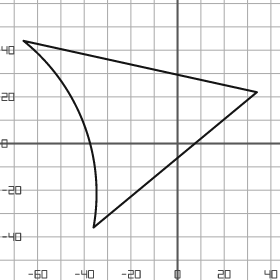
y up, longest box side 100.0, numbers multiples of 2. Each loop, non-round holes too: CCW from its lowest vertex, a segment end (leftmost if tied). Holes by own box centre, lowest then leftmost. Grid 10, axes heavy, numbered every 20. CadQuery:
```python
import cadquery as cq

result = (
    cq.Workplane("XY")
    .moveTo(-36.0, -36.0)
    .lineTo(34.0, 22.0)
    .lineTo(-66.0, 44.0)
    .threePointArc((-40.0, 8.0), (-36.0, -36.0))
    .close()
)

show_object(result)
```